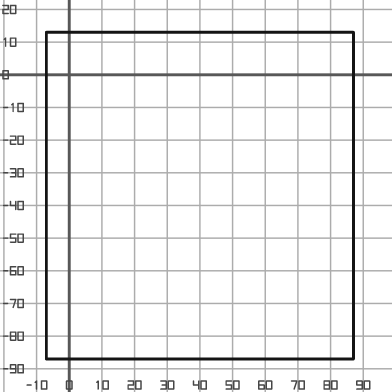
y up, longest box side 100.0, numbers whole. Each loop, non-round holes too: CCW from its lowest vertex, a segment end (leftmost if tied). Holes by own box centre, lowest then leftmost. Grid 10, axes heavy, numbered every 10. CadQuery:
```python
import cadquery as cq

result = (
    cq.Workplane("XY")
    .moveTo(-7.0, -87.0)
    .lineTo(87.0, -87.0)
    .lineTo(87.0, 13.0)
    .lineTo(-7.0, 13.0)
    .close()
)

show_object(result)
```